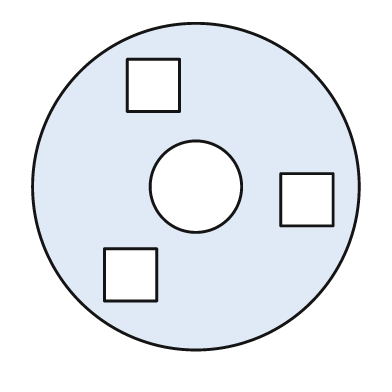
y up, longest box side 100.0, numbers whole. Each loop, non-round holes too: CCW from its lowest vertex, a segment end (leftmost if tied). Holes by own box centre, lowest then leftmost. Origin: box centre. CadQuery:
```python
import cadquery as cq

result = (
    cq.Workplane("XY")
    .moveTo(0.0, 0.0)
    .circle(50.0)
    .moveTo(-28.0, -35.0)
    .lineTo(-12.0, -35.0)
    .lineTo(-12.0, -19.0)
    .lineTo(-28.0, -19.0)
    .close()
    .moveTo(26.0, -12.0)
    .lineTo(42.0, -12.0)
    .lineTo(42.0, 4.0)
    .lineTo(26.0, 4.0)
    .close()
    .moveTo(0.0, 0.0)
    .circle(14.0)
    .moveTo(-21.0, 23.0)
    .lineTo(-5.0, 23.0)
    .lineTo(-5.0, 39.0)
    .lineTo(-21.0, 39.0)
    .close()
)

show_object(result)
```